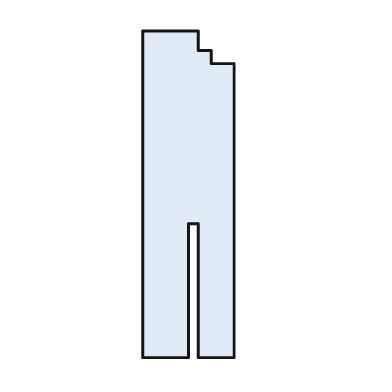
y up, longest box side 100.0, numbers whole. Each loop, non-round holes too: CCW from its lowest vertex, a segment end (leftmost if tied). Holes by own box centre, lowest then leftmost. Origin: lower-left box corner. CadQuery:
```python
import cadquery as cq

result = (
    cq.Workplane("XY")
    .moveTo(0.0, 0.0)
    .lineTo(14.0, 0.0)
    .lineTo(14.0, 41.0)
    .lineTo(17.0, 41.0)
    .lineTo(17.0, 0.0)
    .lineTo(28.0, 0.0)
    .lineTo(28.0, 90.0)
    .lineTo(21.0, 90.0)
    .lineTo(21.0, 94.0)
    .lineTo(17.0, 94.0)
    .lineTo(17.0, 100.0)
    .lineTo(0.0, 100.0)
    .close()
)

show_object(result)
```